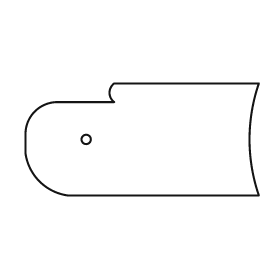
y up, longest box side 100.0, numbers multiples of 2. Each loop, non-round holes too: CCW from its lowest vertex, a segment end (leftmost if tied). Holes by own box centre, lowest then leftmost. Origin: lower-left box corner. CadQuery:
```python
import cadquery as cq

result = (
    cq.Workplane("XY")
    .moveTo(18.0, 0.0)
    .lineTo(100.0, 0.0)
    .threePointArc((96.0, 24.0), (100.0, 48.0))
    .lineTo(38.0, 48.0)
    .threePointArc((36.0, 44.0), (38.0, 40.0))
    .lineTo(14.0, 40.0)
    .threePointArc((4.0, 36.0), (0.0, 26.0))
    .lineTo(0.0, 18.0)
    .threePointArc((6.0, 6.0), (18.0, 0.0))
    .close()
    .moveTo(26.0, 24.0)
    .circle(2.0)
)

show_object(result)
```